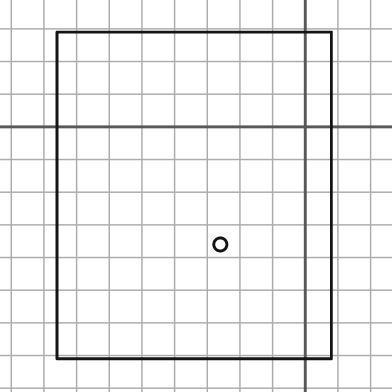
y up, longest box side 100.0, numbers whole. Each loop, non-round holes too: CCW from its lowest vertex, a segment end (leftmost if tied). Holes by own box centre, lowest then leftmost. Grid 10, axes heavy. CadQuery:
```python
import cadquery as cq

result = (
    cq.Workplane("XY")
    .moveTo(-76.0, -71.0)
    .lineTo(8.0, -71.0)
    .lineTo(8.0, 29.0)
    .lineTo(-76.0, 29.0)
    .close()
    .moveTo(-26.0, -36.0)
    .circle(2.0)
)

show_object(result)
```